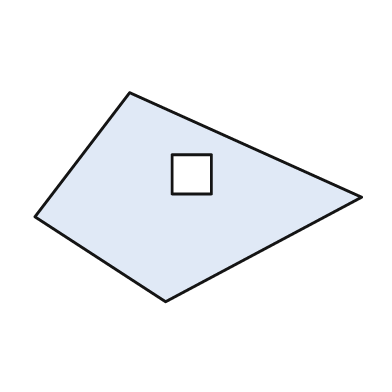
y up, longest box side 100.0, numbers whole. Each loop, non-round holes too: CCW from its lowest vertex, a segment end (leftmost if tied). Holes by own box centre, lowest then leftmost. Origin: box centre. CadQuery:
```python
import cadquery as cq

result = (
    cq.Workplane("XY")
    .moveTo(-10.0, -32.0)
    .lineTo(50.0, 0.0)
    .lineTo(-21.0, 32.0)
    .lineTo(-50.0, -6.0)
    .close()
    .moveTo(-8.0, 1.0)
    .lineTo(4.0, 1.0)
    .lineTo(4.0, 13.0)
    .lineTo(-8.0, 13.0)
    .close()
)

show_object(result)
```